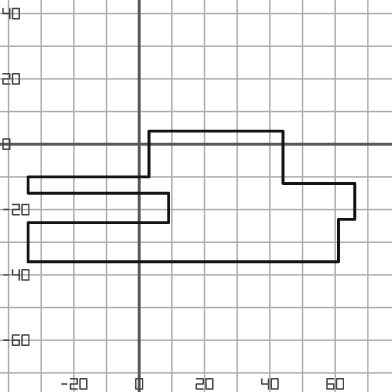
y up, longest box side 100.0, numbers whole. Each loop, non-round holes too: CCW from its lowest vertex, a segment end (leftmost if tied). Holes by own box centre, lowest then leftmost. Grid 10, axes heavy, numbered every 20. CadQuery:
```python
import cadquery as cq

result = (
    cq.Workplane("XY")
    .moveTo(-34.0, -36.0)
    .lineTo(61.0, -36.0)
    .lineTo(61.0, -23.0)
    .lineTo(66.0, -23.0)
    .lineTo(66.0, -12.0)
    .lineTo(44.0, -12.0)
    .lineTo(44.0, 4.0)
    .lineTo(3.0, 4.0)
    .lineTo(3.0, -10.0)
    .lineTo(-34.0, -10.0)
    .lineTo(-34.0, -15.0)
    .lineTo(9.0, -15.0)
    .lineTo(9.0, -24.0)
    .lineTo(-34.0, -24.0)
    .close()
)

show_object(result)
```